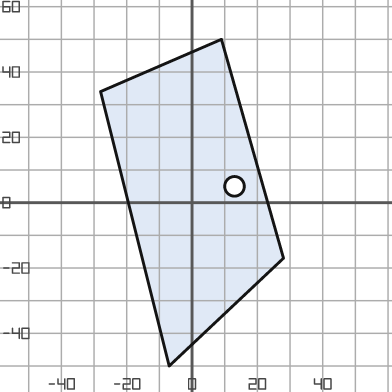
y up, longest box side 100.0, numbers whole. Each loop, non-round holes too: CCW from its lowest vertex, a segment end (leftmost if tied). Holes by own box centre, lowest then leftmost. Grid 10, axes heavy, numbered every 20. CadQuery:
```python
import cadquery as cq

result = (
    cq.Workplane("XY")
    .moveTo(-7.0, -50.0)
    .lineTo(28.0, -17.0)
    .lineTo(9.0, 50.0)
    .lineTo(-28.0, 34.0)
    .close()
    .moveTo(13.0, 5.0)
    .circle(3.0)
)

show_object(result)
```